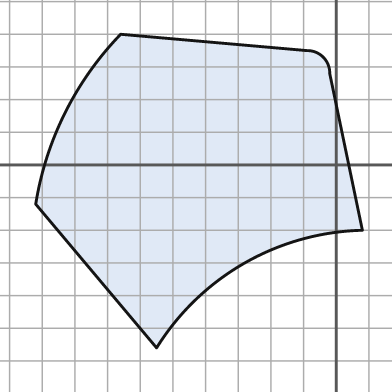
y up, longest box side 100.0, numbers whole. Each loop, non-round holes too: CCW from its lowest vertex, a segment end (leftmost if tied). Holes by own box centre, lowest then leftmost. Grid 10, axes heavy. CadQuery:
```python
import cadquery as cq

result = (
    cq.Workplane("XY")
    .moveTo(-55.0, -56.0)
    .threePointArc((-28.0, -30.0), (8.0, -20.0))
    .lineTo(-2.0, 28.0)
    .threePointArc((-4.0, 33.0), (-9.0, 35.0))
    .lineTo(-66.0, 40.0)
    .threePointArc((-83.0, 16.0), (-92.0, -12.0))
    .close()
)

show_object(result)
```